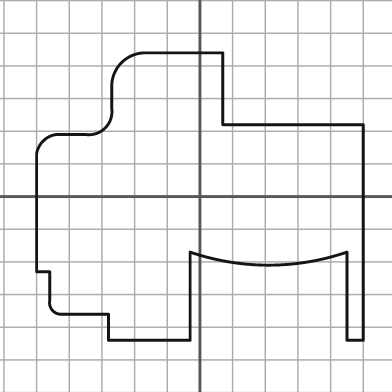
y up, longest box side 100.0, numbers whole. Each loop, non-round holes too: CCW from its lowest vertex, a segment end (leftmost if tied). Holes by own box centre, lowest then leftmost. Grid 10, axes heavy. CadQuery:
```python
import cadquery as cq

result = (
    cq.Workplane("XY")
    .moveTo(-28.0, -44.0)
    .lineTo(-3.0, -44.0)
    .lineTo(-3.0, -17.0)
    .threePointArc((21.0, -21.0), (45.0, -17.0))
    .lineTo(45.0, -44.0)
    .lineTo(50.0, -44.0)
    .lineTo(50.0, 22.0)
    .lineTo(7.0, 22.0)
    .lineTo(7.0, 44.0)
    .lineTo(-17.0, 44.0)
    .threePointArc((-24.0, 41.0), (-27.0, 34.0))
    .lineTo(-27.0, 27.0)
    .threePointArc((-29.0, 21.0), (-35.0, 19.0))
    .lineTo(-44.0, 19.0)
    .threePointArc((-48.0, 17.0), (-50.0, 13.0))
    .lineTo(-50.0, -23.0)
    .lineTo(-46.0, -23.0)
    .lineTo(-46.0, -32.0)
    .threePointArc((-45.0, -35.0), (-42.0, -36.0))
    .lineTo(-28.0, -36.0)
    .close()
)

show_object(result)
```